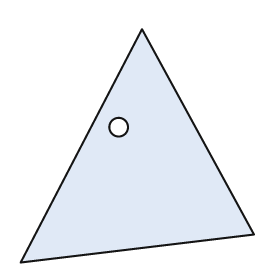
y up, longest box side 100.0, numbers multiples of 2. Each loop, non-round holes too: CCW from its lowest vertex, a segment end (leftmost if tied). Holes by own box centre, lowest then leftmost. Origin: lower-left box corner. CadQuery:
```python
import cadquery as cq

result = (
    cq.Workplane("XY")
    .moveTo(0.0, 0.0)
    .lineTo(100.0, 12.0)
    .lineTo(52.0, 100.0)
    .close()
    .moveTo(42.0, 58.0)
    .circle(4.0)
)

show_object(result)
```